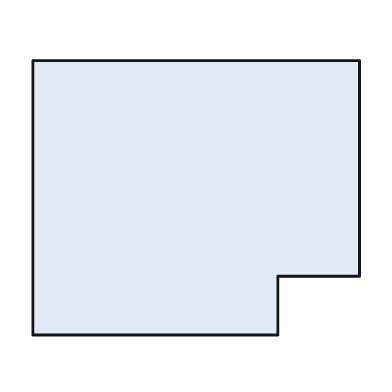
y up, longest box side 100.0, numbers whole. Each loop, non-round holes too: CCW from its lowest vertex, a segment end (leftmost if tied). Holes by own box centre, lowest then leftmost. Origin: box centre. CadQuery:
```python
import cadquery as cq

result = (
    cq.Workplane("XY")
    .moveTo(-50.0, -42.0)
    .lineTo(25.0, -42.0)
    .lineTo(25.0, -24.0)
    .lineTo(50.0, -24.0)
    .lineTo(50.0, 42.0)
    .lineTo(-50.0, 42.0)
    .close()
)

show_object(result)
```